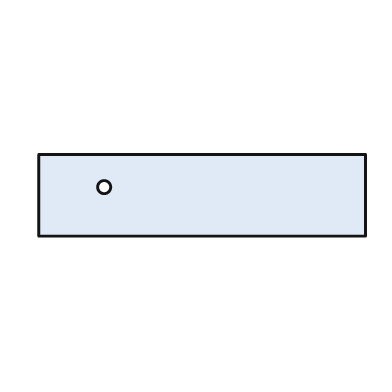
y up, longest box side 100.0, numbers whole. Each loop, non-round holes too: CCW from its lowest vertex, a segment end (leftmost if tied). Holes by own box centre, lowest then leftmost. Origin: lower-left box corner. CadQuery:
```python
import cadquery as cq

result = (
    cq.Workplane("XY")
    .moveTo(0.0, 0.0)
    .lineTo(100.0, 0.0)
    .lineTo(100.0, 25.0)
    .lineTo(0.0, 25.0)
    .close()
    .moveTo(20.0, 15.0)
    .circle(2.0)
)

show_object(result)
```